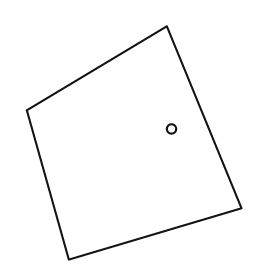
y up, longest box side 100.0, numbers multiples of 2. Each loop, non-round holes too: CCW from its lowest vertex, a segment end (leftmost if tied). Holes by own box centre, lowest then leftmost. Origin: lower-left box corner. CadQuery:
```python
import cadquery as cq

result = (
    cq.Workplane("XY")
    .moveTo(18.0, 0.0)
    .lineTo(92.0, 22.0)
    .lineTo(60.0, 100.0)
    .lineTo(0.0, 64.0)
    .close()
    .moveTo(62.0, 56.0)
    .circle(2.0)
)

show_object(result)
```